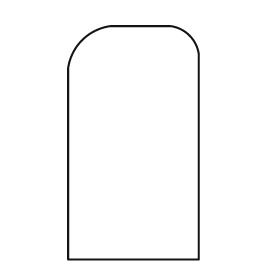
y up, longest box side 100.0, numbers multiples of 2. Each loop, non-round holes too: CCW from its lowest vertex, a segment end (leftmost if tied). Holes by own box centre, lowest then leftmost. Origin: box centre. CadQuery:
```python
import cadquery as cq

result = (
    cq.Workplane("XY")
    .moveTo(-28.0, -50.0)
    .lineTo(28.0, -50.0)
    .lineTo(28.0, 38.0)
    .threePointArc((24.0, 46.0), (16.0, 50.0))
    .lineTo(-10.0, 50.0)
    .threePointArc((-22.0, 44.0), (-28.0, 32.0))
    .close()
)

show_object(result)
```